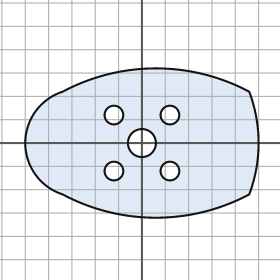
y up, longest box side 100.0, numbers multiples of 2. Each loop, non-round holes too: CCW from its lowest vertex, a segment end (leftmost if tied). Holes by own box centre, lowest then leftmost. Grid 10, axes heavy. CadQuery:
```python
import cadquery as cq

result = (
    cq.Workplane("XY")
    .moveTo(-34.0, -22.0)
    .threePointArc((6.0, -32.0), (46.0, -22.0))
    .threePointArc((50.0, 0.0), (46.0, 22.0))
    .threePointArc((6.0, 32.0), (-34.0, 22.0))
    .threePointArc((-50.0, 0.0), (-34.0, -22.0))
    .close()
    .moveTo(-12.0, -12.0)
    .circle(4.0)
    .moveTo(12.0, -12.0)
    .circle(4.0)
    .moveTo(0.0, 0.0)
    .circle(6.0)
    .moveTo(-12.0, 12.0)
    .circle(4.0)
    .moveTo(12.0, 12.0)
    .circle(4.0)
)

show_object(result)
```